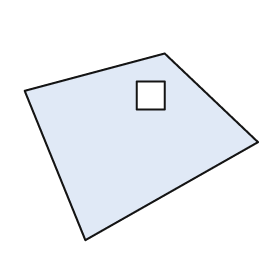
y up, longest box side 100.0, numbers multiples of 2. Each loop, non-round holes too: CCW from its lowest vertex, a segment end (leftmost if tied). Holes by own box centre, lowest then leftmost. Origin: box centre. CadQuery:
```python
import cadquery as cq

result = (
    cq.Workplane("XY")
    .moveTo(-24.0, -40.0)
    .lineTo(50.0, 2.0)
    .lineTo(10.0, 40.0)
    .lineTo(-50.0, 24.0)
    .close()
    .moveTo(-2.0, 16.0)
    .lineTo(10.0, 16.0)
    .lineTo(10.0, 28.0)
    .lineTo(-2.0, 28.0)
    .close()
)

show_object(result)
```